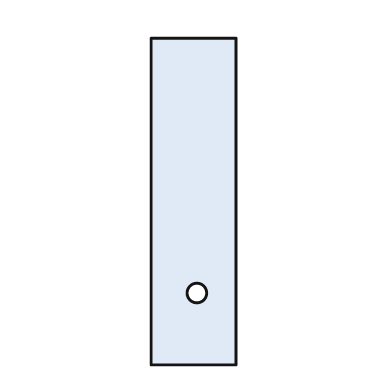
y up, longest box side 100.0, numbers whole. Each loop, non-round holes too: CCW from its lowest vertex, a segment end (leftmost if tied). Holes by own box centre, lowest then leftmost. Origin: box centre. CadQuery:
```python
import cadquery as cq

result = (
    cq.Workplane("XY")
    .moveTo(-13.0, -50.0)
    .lineTo(13.0, -50.0)
    .lineTo(13.0, 50.0)
    .lineTo(-13.0, 50.0)
    .close()
    .moveTo(1.0, -28.0)
    .circle(3.0)
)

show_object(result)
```